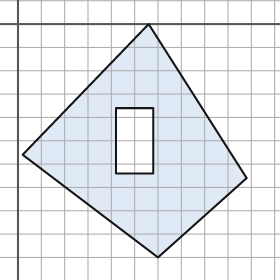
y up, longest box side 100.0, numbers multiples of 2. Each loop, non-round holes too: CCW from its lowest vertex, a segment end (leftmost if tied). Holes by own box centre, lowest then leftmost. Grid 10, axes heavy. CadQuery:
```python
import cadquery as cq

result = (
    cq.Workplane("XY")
    .moveTo(60.0, -100.0)
    .lineTo(98.0, -66.0)
    .lineTo(56.0, 0.0)
    .lineTo(2.0, -56.0)
    .close()
    .moveTo(42.0, -64.0)
    .lineTo(58.0, -64.0)
    .lineTo(58.0, -36.0)
    .lineTo(42.0, -36.0)
    .close()
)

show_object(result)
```